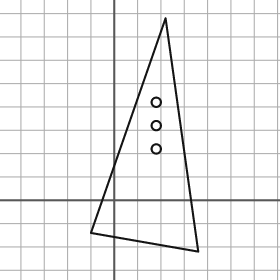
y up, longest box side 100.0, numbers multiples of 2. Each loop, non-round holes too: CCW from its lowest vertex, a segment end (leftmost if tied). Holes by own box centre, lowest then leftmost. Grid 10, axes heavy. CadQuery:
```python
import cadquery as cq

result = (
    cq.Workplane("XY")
    .moveTo(36.0, -22.0)
    .lineTo(22.0, 78.0)
    .lineTo(-10.0, -14.0)
    .close()
    .moveTo(18.0, 22.0)
    .circle(2.0)
    .moveTo(18.0, 32.0)
    .circle(2.0)
    .moveTo(18.0, 42.0)
    .circle(2.0)
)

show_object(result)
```